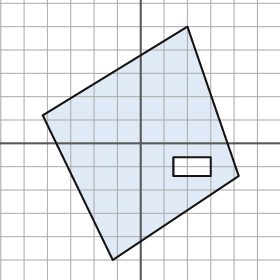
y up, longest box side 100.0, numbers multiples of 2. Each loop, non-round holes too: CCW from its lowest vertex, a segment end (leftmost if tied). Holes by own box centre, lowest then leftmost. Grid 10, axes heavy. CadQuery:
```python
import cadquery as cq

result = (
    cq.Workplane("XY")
    .moveTo(-12.0, -50.0)
    .lineTo(42.0, -14.0)
    .lineTo(20.0, 50.0)
    .lineTo(-42.0, 12.0)
    .close()
    .moveTo(14.0, -14.0)
    .lineTo(30.0, -14.0)
    .lineTo(30.0, -6.0)
    .lineTo(14.0, -6.0)
    .close()
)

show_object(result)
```